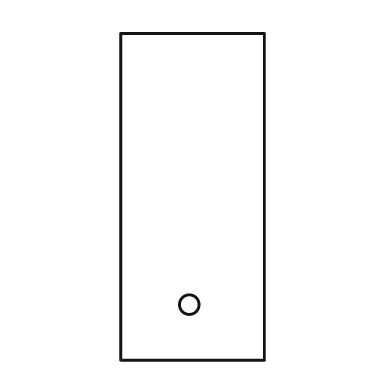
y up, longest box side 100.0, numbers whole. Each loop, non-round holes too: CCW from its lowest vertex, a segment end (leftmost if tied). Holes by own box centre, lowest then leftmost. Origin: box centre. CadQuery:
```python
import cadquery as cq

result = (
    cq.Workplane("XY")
    .moveTo(-22.0, -50.0)
    .lineTo(22.0, -50.0)
    .lineTo(22.0, 50.0)
    .lineTo(-22.0, 50.0)
    .close()
    .moveTo(-1.0, -33.0)
    .circle(3.0)
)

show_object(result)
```